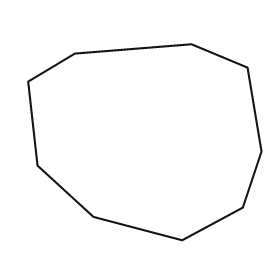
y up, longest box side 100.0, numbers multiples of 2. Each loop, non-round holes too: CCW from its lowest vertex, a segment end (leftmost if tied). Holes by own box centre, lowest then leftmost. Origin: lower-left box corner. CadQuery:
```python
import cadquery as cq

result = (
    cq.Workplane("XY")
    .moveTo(66.0, 0.0)
    .lineTo(92.0, 14.0)
    .lineTo(100.0, 38.0)
    .lineTo(94.0, 74.0)
    .lineTo(70.0, 84.0)
    .lineTo(20.0, 80.0)
    .lineTo(0.0, 68.0)
    .lineTo(4.0, 32.0)
    .lineTo(28.0, 10.0)
    .close()
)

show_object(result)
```